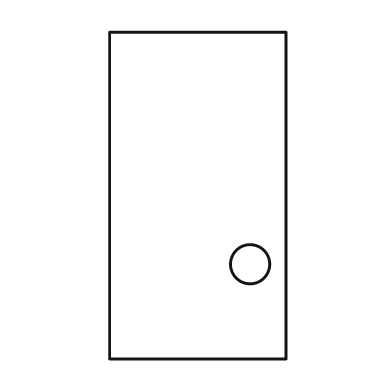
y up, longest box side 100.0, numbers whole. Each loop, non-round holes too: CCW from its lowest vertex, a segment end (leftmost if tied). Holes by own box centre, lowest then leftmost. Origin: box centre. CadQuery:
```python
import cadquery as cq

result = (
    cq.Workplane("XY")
    .moveTo(-27.0, -50.0)
    .lineTo(27.0, -50.0)
    .lineTo(27.0, 50.0)
    .lineTo(-27.0, 50.0)
    .close()
    .moveTo(16.0, -21.0)
    .circle(6.0)
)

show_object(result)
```